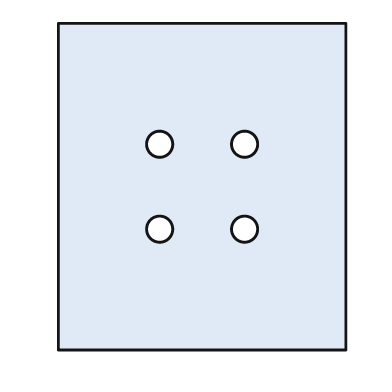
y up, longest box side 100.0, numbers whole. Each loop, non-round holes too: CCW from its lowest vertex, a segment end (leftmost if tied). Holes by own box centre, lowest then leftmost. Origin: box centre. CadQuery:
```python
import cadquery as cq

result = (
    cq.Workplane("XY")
    .moveTo(-44.0, -50.0)
    .lineTo(44.0, -50.0)
    .lineTo(44.0, 50.0)
    .lineTo(-44.0, 50.0)
    .close()
    .moveTo(-13.0, -13.0)
    .circle(4.0)
    .moveTo(13.0, -13.0)
    .circle(4.0)
    .moveTo(-13.0, 13.0)
    .circle(4.0)
    .moveTo(13.0, 13.0)
    .circle(4.0)
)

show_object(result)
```